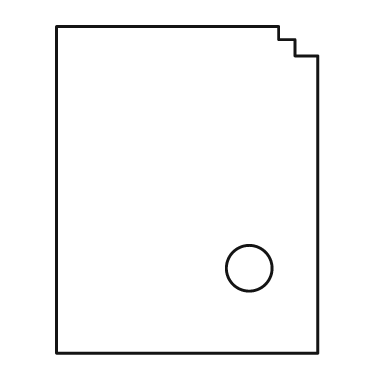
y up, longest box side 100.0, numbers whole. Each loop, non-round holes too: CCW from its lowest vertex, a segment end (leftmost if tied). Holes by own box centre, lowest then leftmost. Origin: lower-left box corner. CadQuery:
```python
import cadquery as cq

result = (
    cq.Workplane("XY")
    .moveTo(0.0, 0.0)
    .lineTo(80.0, 0.0)
    .lineTo(80.0, 91.0)
    .lineTo(73.0, 91.0)
    .lineTo(73.0, 96.0)
    .lineTo(68.0, 96.0)
    .lineTo(68.0, 100.0)
    .lineTo(0.0, 100.0)
    .close()
    .moveTo(59.0, 26.0)
    .circle(7.0)
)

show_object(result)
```